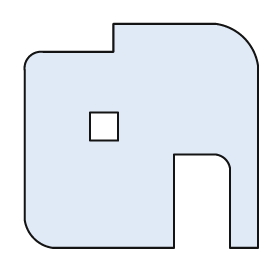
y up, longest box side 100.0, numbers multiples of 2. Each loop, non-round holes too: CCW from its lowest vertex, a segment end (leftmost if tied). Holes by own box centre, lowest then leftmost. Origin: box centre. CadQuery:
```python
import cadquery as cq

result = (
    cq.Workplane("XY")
    .moveTo(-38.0, -48.0)
    .lineTo(14.0, -48.0)
    .lineTo(14.0, -8.0)
    .lineTo(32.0, -8.0)
    .threePointArc((36.0, -10.0), (38.0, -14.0))
    .lineTo(38.0, -48.0)
    .lineTo(50.0, -48.0)
    .lineTo(50.0, 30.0)
    .threePointArc((44.0, 42.0), (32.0, 48.0))
    .lineTo(-12.0, 48.0)
    .lineTo(-12.0, 36.0)
    .lineTo(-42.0, 36.0)
    .threePointArc((-48.0, 34.0), (-50.0, 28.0))
    .lineTo(-50.0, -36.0)
    .threePointArc((-46.0, -44.0), (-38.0, -48.0))
    .close()
    .moveTo(-22.0, -2.0)
    .lineTo(-10.0, -2.0)
    .lineTo(-10.0, 10.0)
    .lineTo(-22.0, 10.0)
    .close()
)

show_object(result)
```